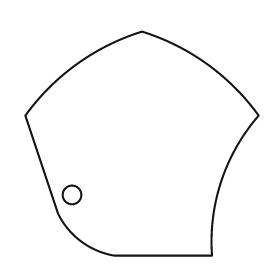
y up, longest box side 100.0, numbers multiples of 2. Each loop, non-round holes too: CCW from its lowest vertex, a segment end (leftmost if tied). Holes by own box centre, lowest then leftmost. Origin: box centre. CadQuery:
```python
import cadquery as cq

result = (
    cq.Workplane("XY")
    .moveTo(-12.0, -48.0)
    .lineTo(30.0, -48.0)
    .threePointArc((34.0, -16.0), (50.0, 12.0))
    .threePointArc((28.0, 34.0), (0.0, 48.0))
    .threePointArc((-28.0, 34.0), (-50.0, 12.0))
    .lineTo(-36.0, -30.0)
    .threePointArc((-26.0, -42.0), (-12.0, -48.0))
    .close()
    .moveTo(-30.0, -22.0)
    .circle(4.0)
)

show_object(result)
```